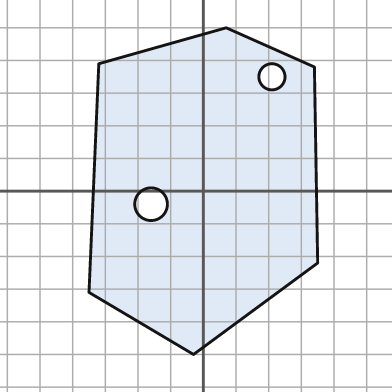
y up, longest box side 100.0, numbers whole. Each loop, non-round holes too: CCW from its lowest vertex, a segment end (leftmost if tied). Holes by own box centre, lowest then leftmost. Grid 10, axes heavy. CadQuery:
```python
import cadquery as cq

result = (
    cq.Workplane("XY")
    .moveTo(-3.0, -50.0)
    .lineTo(35.0, -22.0)
    .lineTo(34.0, 38.0)
    .lineTo(7.0, 50.0)
    .lineTo(-32.0, 39.0)
    .lineTo(-35.0, -31.0)
    .close()
    .moveTo(-16.0, -4.0)
    .circle(5.0)
    .moveTo(21.0, 35.0)
    .circle(4.0)
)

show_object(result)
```